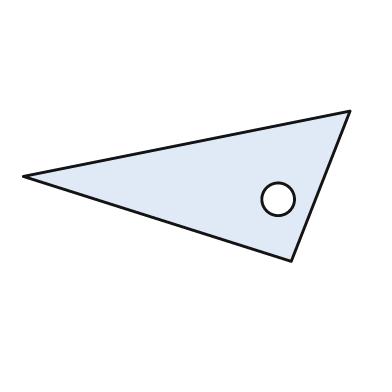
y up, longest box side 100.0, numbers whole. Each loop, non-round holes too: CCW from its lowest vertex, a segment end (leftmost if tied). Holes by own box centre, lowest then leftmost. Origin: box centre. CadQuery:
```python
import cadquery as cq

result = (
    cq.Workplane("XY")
    .moveTo(32.0, -23.0)
    .lineTo(50.0, 23.0)
    .lineTo(-50.0, 3.0)
    .close()
    .moveTo(28.0, -4.0)
    .circle(5.0)
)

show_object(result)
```